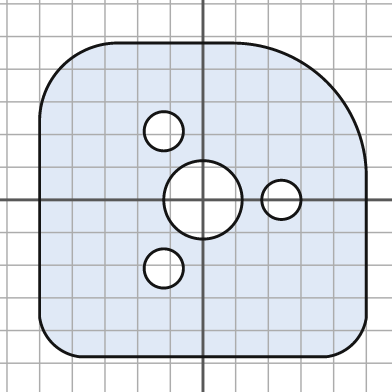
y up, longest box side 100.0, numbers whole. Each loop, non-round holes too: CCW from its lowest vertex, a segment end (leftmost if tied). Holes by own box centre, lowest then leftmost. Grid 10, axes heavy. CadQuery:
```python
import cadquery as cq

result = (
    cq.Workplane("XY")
    .moveTo(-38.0, -48.0)
    .lineTo(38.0, -48.0)
    .threePointArc((46.0, -44.0), (50.0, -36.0))
    .lineTo(50.0, 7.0)
    .threePointArc((38.0, 36.0), (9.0, 48.0))
    .lineTo(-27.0, 48.0)
    .threePointArc((-43.0, 41.0), (-50.0, 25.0))
    .lineTo(-50.0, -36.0)
    .threePointArc((-46.0, -44.0), (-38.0, -48.0))
    .close()
    .moveTo(-12.0, -21.0)
    .circle(6.0)
    .moveTo(0.0, 0.0)
    .circle(12.0)
    .moveTo(24.0, 0.0)
    .circle(6.0)
    .moveTo(-12.0, 21.0)
    .circle(6.0)
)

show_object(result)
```